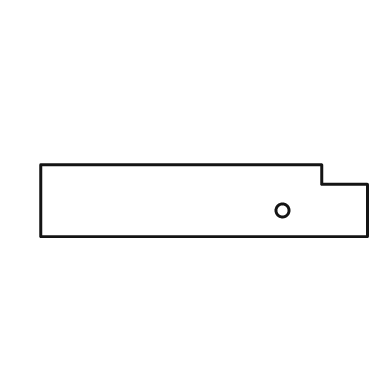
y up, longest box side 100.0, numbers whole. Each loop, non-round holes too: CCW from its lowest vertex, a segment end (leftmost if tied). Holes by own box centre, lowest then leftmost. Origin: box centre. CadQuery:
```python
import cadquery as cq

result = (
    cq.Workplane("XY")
    .moveTo(-50.0, -11.0)
    .lineTo(50.0, -11.0)
    .lineTo(50.0, 5.0)
    .lineTo(36.0, 5.0)
    .lineTo(36.0, 11.0)
    .lineTo(-50.0, 11.0)
    .close()
    .moveTo(24.0, -3.0)
    .circle(2.0)
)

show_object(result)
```